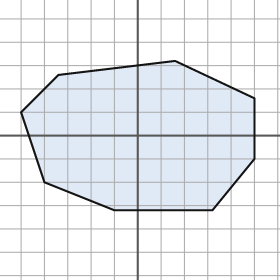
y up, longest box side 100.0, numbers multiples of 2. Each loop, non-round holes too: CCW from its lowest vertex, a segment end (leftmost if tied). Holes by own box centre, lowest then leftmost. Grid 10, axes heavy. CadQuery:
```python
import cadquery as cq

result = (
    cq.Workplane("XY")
    .moveTo(-10.0, -32.0)
    .lineTo(32.0, -32.0)
    .lineTo(50.0, -10.0)
    .lineTo(50.0, 16.0)
    .lineTo(16.0, 32.0)
    .lineTo(-34.0, 26.0)
    .lineTo(-50.0, 10.0)
    .lineTo(-40.0, -20.0)
    .close()
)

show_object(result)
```